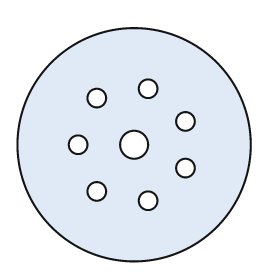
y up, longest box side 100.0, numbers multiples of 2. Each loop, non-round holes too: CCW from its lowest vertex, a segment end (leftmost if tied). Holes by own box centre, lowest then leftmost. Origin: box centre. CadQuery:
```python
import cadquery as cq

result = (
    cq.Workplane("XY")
    .moveTo(0.0, 0.0)
    .circle(50.0)
    .moveTo(6.0, -24.0)
    .circle(4.0)
    .moveTo(-16.0, -20.0)
    .circle(4.0)
    .moveTo(22.0, -10.0)
    .circle(4.0)
    .moveTo(-24.0, 0.0)
    .circle(4.0)
    .moveTo(0.0, 0.0)
    .circle(6.0)
    .moveTo(22.0, 10.0)
    .circle(4.0)
    .moveTo(-16.0, 20.0)
    .circle(4.0)
    .moveTo(6.0, 24.0)
    .circle(4.0)
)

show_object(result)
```